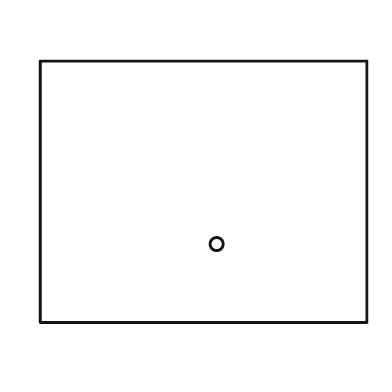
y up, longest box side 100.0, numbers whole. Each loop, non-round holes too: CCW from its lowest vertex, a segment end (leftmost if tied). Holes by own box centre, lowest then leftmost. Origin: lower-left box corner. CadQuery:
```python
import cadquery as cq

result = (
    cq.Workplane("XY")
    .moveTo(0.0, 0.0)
    .lineTo(100.0, 0.0)
    .lineTo(100.0, 80.0)
    .lineTo(0.0, 80.0)
    .close()
    .moveTo(54.0, 24.0)
    .circle(2.0)
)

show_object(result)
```